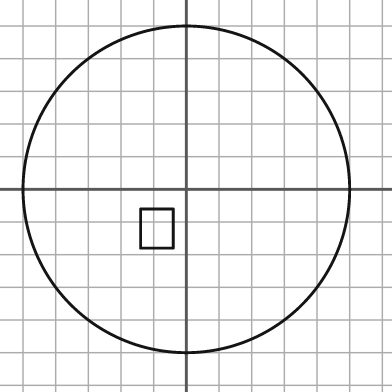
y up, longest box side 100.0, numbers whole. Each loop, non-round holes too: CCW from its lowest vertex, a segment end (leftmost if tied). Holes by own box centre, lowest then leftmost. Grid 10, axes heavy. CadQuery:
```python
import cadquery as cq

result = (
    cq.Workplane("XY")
    .moveTo(0.0, 0.0)
    .circle(50.0)
    .moveTo(-14.0, -18.0)
    .lineTo(-4.0, -18.0)
    .lineTo(-4.0, -6.0)
    .lineTo(-14.0, -6.0)
    .close()
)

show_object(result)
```